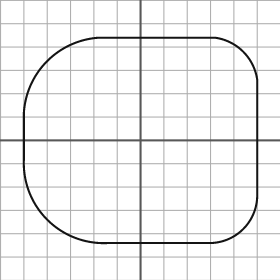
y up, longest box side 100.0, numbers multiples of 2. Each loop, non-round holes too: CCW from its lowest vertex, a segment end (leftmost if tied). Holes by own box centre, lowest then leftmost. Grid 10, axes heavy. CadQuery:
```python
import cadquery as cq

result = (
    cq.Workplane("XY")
    .moveTo(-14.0, -44.0)
    .lineTo(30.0, -44.0)
    .threePointArc((44.0, -38.0), (50.0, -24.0))
    .lineTo(50.0, 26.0)
    .threePointArc((44.0, 38.0), (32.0, 44.0))
    .lineTo(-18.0, 44.0)
    .threePointArc((-40.0, 34.0), (-50.0, 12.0))
    .lineTo(-50.0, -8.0)
    .threePointArc((-40.0, -34.0), (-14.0, -44.0))
    .close()
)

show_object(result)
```